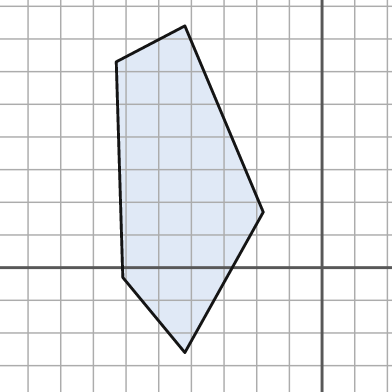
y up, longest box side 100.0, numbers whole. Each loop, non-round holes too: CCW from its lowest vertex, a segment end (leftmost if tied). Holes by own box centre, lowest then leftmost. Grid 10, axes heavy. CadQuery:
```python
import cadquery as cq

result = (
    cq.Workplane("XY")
    .moveTo(-42.0, -26.0)
    .lineTo(-18.0, 17.0)
    .lineTo(-42.0, 74.0)
    .lineTo(-63.0, 63.0)
    .lineTo(-61.0, -3.0)
    .close()
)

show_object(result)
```